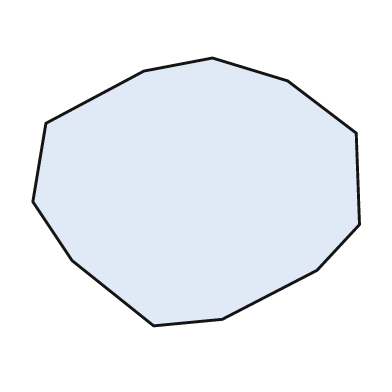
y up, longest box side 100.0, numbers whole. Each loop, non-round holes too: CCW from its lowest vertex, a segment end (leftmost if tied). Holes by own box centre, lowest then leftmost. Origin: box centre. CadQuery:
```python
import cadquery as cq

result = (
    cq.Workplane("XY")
    .moveTo(-13.0, -41.0)
    .lineTo(8.0, -39.0)
    .lineTo(37.0, -24.0)
    .lineTo(50.0, -10.0)
    .lineTo(49.0, 18.0)
    .lineTo(28.0, 34.0)
    .lineTo(5.0, 41.0)
    .lineTo(-16.0, 37.0)
    .lineTo(-46.0, 21.0)
    .lineTo(-50.0, -3.0)
    .lineTo(-38.0, -21.0)
    .close()
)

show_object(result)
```